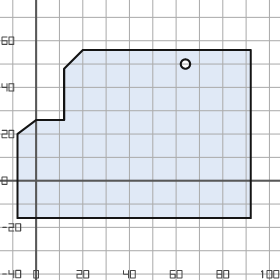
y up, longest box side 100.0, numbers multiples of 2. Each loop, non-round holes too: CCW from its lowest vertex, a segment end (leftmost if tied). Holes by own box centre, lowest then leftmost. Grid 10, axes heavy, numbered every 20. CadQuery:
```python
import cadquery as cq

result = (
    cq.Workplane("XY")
    .moveTo(-8.0, -16.0)
    .lineTo(92.0, -16.0)
    .lineTo(92.0, 56.0)
    .lineTo(20.0, 56.0)
    .lineTo(12.0, 48.0)
    .lineTo(12.0, 26.0)
    .lineTo(0.0, 26.0)
    .lineTo(-8.0, 20.0)
    .close()
    .moveTo(64.0, 50.0)
    .circle(2.0)
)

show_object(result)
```